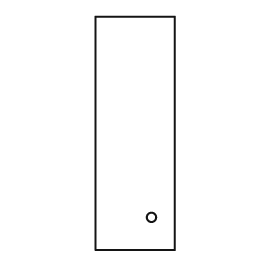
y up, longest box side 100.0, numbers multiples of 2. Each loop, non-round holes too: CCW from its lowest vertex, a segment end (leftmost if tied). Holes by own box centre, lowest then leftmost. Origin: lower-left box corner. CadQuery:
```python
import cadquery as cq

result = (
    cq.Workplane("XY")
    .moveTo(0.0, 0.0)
    .lineTo(34.0, 0.0)
    .lineTo(34.0, 100.0)
    .lineTo(0.0, 100.0)
    .close()
    .moveTo(24.0, 14.0)
    .circle(2.0)
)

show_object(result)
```